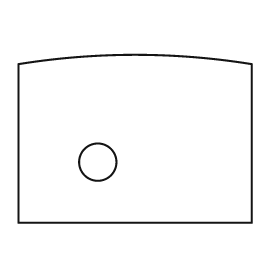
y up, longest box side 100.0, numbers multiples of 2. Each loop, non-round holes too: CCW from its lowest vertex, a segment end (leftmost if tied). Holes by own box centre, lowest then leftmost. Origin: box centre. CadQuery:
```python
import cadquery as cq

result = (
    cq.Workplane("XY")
    .moveTo(-50.0, -36.0)
    .lineTo(50.0, -36.0)
    .lineTo(50.0, 32.0)
    .threePointArc((0.0, 36.0), (-50.0, 32.0))
    .close()
    .moveTo(-16.0, -10.0)
    .circle(8.0)
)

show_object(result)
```